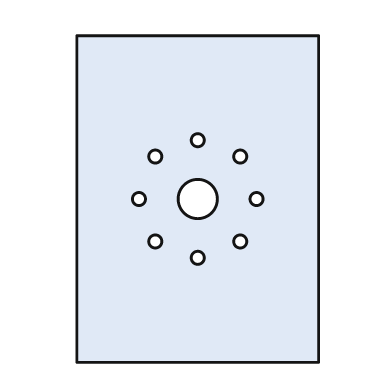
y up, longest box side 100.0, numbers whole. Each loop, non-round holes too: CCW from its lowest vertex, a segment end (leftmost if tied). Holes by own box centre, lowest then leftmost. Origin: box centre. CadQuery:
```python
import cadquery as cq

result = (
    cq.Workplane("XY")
    .moveTo(-37.0, -50.0)
    .lineTo(37.0, -50.0)
    .lineTo(37.0, 50.0)
    .lineTo(-37.0, 50.0)
    .close()
    .moveTo(0.0, -18.0)
    .circle(2.0)
    .moveTo(-13.0, -13.0)
    .circle(2.0)
    .moveTo(13.0, -13.0)
    .circle(2.0)
    .moveTo(-18.0, 0.0)
    .circle(2.0)
    .moveTo(0.0, 0.0)
    .circle(6.0)
    .moveTo(18.0, 0.0)
    .circle(2.0)
    .moveTo(-13.0, 13.0)
    .circle(2.0)
    .moveTo(13.0, 13.0)
    .circle(2.0)
    .moveTo(0.0, 18.0)
    .circle(2.0)
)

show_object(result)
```